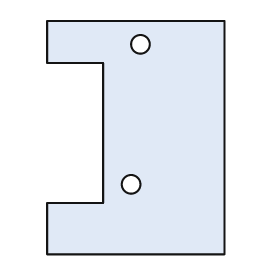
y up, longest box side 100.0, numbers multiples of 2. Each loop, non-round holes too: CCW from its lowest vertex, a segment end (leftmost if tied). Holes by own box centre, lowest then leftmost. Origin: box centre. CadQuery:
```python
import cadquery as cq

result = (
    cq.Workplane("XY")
    .moveTo(-38.0, -50.0)
    .lineTo(38.0, -50.0)
    .lineTo(38.0, 50.0)
    .lineTo(-38.0, 50.0)
    .lineTo(-38.0, 32.0)
    .lineTo(-14.0, 32.0)
    .lineTo(-14.0, -28.0)
    .lineTo(-38.0, -28.0)
    .close()
    .moveTo(-2.0, -20.0)
    .circle(4.0)
    .moveTo(2.0, 40.0)
    .circle(4.0)
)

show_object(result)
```